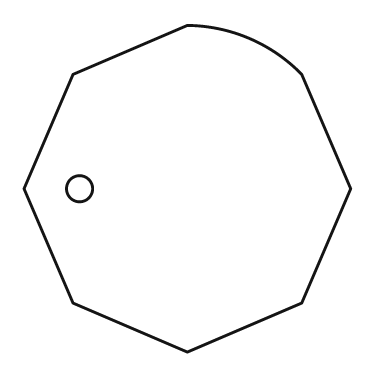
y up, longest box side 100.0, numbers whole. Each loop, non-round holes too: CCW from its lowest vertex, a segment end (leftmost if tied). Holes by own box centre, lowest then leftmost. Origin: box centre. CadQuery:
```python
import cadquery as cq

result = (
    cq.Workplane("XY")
    .moveTo(0.0, -50.0)
    .lineTo(35.0, -35.0)
    .lineTo(50.0, 0.0)
    .lineTo(35.0, 35.0)
    .threePointArc((19.0, 46.0), (0.0, 50.0))
    .lineTo(-35.0, 35.0)
    .lineTo(-50.0, 0.0)
    .lineTo(-35.0, -35.0)
    .close()
    .moveTo(-33.0, 0.0)
    .circle(4.0)
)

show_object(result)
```